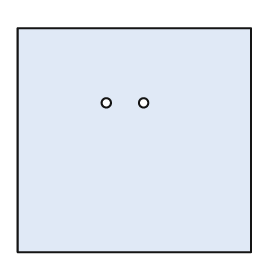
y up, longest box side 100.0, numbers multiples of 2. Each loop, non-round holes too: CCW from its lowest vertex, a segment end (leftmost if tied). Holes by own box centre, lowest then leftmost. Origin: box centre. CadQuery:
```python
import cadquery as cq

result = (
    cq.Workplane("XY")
    .moveTo(-50.0, -48.0)
    .lineTo(50.0, -48.0)
    .lineTo(50.0, 48.0)
    .lineTo(-50.0, 48.0)
    .close()
    .moveTo(-12.0, 16.0)
    .circle(2.0)
    .moveTo(4.0, 16.0)
    .circle(2.0)
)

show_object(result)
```